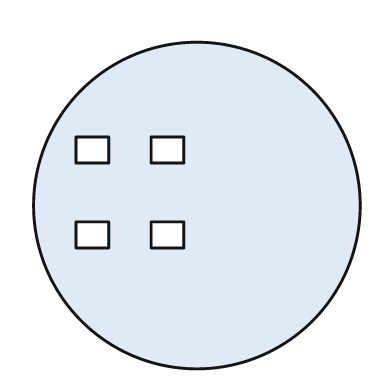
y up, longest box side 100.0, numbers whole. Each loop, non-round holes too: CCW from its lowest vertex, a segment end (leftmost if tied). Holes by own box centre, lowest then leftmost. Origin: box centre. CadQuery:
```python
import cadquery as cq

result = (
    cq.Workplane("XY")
    .moveTo(0.0, 0.0)
    .circle(50.0)
    .moveTo(-37.0, -13.0)
    .lineTo(-27.0, -13.0)
    .lineTo(-27.0, -5.0)
    .lineTo(-37.0, -5.0)
    .close()
    .moveTo(-14.0, -13.0)
    .lineTo(-4.0, -13.0)
    .lineTo(-4.0, -5.0)
    .lineTo(-14.0, -5.0)
    .close()
    .moveTo(-37.0, 13.0)
    .lineTo(-27.0, 13.0)
    .lineTo(-27.0, 21.0)
    .lineTo(-37.0, 21.0)
    .close()
    .moveTo(-14.0, 13.0)
    .lineTo(-4.0, 13.0)
    .lineTo(-4.0, 21.0)
    .lineTo(-14.0, 21.0)
    .close()
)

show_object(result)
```